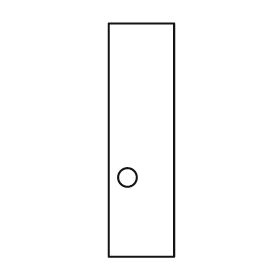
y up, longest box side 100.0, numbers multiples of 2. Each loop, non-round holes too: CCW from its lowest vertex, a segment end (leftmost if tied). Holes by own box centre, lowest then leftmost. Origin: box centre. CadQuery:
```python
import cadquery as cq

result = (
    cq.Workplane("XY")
    .moveTo(-14.0, -50.0)
    .lineTo(14.0, -50.0)
    .lineTo(14.0, 50.0)
    .lineTo(-14.0, 50.0)
    .close()
    .moveTo(-6.0, -16.0)
    .circle(4.0)
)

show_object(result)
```